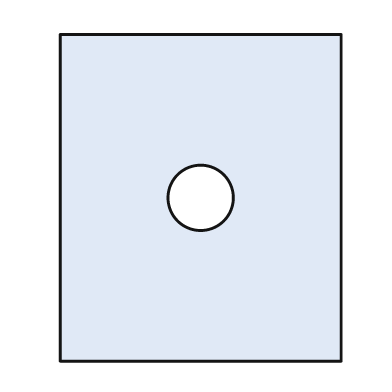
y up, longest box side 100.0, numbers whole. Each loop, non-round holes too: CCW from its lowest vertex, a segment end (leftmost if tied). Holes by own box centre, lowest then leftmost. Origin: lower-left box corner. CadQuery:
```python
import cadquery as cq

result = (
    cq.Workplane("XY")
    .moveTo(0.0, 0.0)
    .lineTo(86.0, 0.0)
    .lineTo(86.0, 100.0)
    .lineTo(0.0, 100.0)
    .close()
    .moveTo(43.0, 50.0)
    .circle(10.0)
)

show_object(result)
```